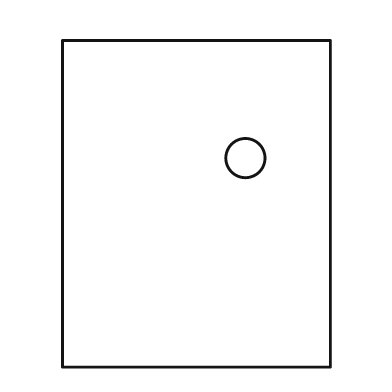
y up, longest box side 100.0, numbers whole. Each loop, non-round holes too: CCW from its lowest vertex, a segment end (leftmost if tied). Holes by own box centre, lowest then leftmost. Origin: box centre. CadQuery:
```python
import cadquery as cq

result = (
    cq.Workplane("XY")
    .moveTo(-41.0, -50.0)
    .lineTo(41.0, -50.0)
    .lineTo(41.0, 50.0)
    .lineTo(-41.0, 50.0)
    .close()
    .moveTo(15.0, 14.0)
    .circle(6.0)
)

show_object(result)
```